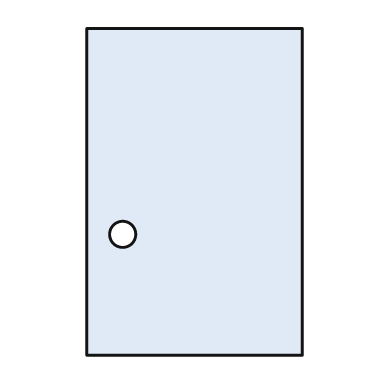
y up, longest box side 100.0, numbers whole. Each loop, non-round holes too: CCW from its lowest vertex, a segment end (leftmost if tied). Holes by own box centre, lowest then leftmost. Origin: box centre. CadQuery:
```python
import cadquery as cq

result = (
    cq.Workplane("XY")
    .moveTo(-33.0, -50.0)
    .lineTo(33.0, -50.0)
    .lineTo(33.0, 50.0)
    .lineTo(-33.0, 50.0)
    .close()
    .moveTo(-22.0, -13.0)
    .circle(4.0)
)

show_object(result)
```